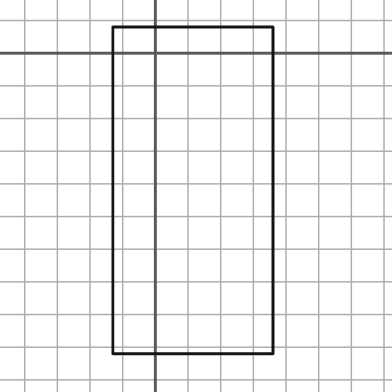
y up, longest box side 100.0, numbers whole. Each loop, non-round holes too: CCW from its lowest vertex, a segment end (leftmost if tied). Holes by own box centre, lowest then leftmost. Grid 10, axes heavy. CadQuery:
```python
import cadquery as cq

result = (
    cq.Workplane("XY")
    .moveTo(-13.0, -92.0)
    .lineTo(36.0, -92.0)
    .lineTo(36.0, 8.0)
    .lineTo(-13.0, 8.0)
    .close()
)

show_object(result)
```